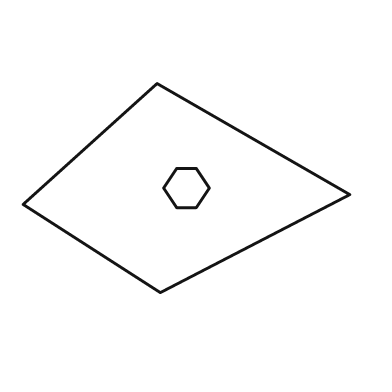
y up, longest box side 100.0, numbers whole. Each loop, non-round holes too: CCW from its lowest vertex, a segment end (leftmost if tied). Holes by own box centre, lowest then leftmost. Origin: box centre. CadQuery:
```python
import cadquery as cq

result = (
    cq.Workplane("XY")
    .moveTo(-8.0, -32.0)
    .lineTo(50.0, -2.0)
    .lineTo(-9.0, 32.0)
    .lineTo(-50.0, -5.0)
    .close()
    .moveTo(-3.0, -6.0)
    .lineTo(3.0, -6.0)
    .lineTo(7.0, 0.0)
    .lineTo(3.0, 6.0)
    .lineTo(-3.0, 6.0)
    .lineTo(-7.0, 0.0)
    .close()
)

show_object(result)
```